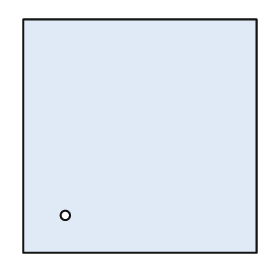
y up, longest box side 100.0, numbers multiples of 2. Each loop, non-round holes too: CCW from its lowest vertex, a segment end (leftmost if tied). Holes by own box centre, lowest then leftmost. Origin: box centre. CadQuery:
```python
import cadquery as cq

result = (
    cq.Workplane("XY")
    .moveTo(-50.0, -50.0)
    .lineTo(50.0, -50.0)
    .lineTo(50.0, 50.0)
    .lineTo(-50.0, 50.0)
    .close()
    .moveTo(-32.0, -34.0)
    .circle(2.0)
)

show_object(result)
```